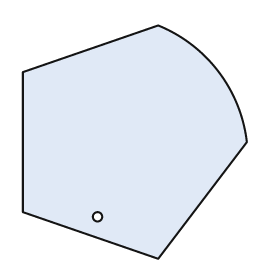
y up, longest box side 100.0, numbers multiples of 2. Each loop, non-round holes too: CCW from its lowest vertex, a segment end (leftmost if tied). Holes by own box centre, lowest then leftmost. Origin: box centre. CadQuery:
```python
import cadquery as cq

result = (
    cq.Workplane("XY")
    .moveTo(10.0, -50.0)
    .lineTo(48.0, 0.0)
    .threePointArc((36.0, 30.0), (10.0, 50.0))
    .lineTo(-48.0, 30.0)
    .lineTo(-48.0, -30.0)
    .close()
    .moveTo(-16.0, -32.0)
    .circle(2.0)
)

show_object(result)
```